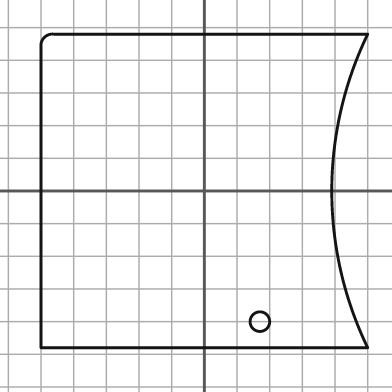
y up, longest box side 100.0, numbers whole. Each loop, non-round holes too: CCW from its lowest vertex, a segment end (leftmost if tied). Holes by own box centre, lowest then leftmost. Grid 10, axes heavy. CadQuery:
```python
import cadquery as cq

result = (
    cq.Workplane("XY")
    .moveTo(-50.0, -48.0)
    .lineTo(50.0, -48.0)
    .threePointArc((39.0, 0.0), (50.0, 48.0))
    .lineTo(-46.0, 48.0)
    .threePointArc((-49.0, 47.0), (-50.0, 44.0))
    .close()
    .moveTo(17.0, -40.0)
    .circle(3.0)
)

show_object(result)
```